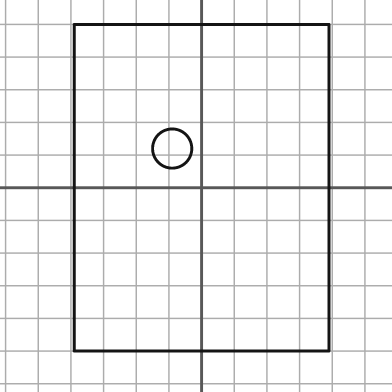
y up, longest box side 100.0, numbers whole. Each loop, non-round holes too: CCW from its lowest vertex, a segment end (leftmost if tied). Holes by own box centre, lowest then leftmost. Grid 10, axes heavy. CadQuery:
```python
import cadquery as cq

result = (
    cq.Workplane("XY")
    .moveTo(-39.0, -50.0)
    .lineTo(39.0, -50.0)
    .lineTo(39.0, 50.0)
    .lineTo(-39.0, 50.0)
    .close()
    .moveTo(-9.0, 12.0)
    .circle(6.0)
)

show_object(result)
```